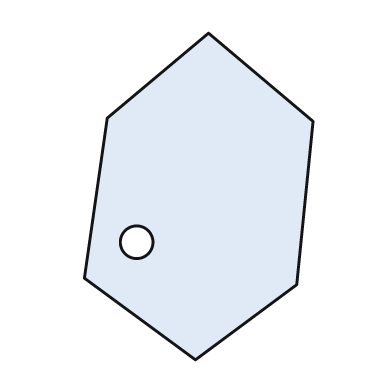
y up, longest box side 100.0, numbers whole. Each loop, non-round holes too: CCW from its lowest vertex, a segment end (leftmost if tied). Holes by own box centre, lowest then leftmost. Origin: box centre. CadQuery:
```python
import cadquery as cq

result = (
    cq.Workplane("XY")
    .moveTo(-1.0, -50.0)
    .lineTo(30.0, -27.0)
    .lineTo(35.0, 23.0)
    .lineTo(3.0, 50.0)
    .lineTo(-28.0, 24.0)
    .lineTo(-35.0, -25.0)
    .close()
    .moveTo(-19.0, -14.0)
    .circle(5.0)
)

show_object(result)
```